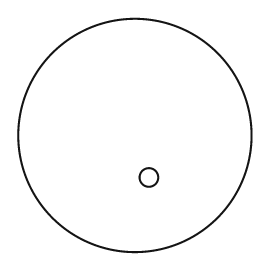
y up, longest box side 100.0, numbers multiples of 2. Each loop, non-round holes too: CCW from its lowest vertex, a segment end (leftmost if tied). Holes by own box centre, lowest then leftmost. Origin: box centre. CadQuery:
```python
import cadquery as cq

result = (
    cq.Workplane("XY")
    .moveTo(0.0, 0.0)
    .circle(50.0)
    .moveTo(6.0, -18.0)
    .circle(4.0)
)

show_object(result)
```